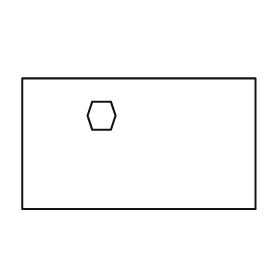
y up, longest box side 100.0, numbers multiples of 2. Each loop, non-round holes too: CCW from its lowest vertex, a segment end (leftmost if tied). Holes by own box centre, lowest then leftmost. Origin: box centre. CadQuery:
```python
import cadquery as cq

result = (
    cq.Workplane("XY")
    .moveTo(-50.0, -28.0)
    .lineTo(50.0, -28.0)
    .lineTo(50.0, 28.0)
    .lineTo(-50.0, 28.0)
    .close()
    .moveTo(-20.0, 6.0)
    .lineTo(-12.0, 6.0)
    .lineTo(-10.0, 12.0)
    .lineTo(-12.0, 18.0)
    .lineTo(-20.0, 18.0)
    .lineTo(-22.0, 12.0)
    .close()
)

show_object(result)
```